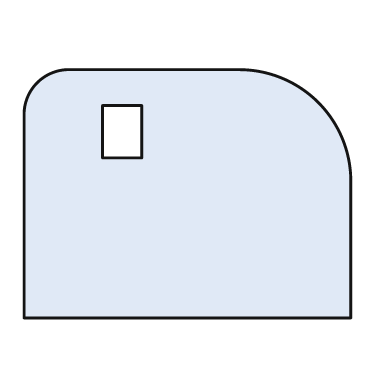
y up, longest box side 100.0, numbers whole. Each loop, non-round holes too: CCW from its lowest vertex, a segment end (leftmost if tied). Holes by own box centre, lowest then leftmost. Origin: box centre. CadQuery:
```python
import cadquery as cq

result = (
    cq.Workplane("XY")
    .moveTo(-50.0, -38.0)
    .lineTo(50.0, -38.0)
    .lineTo(50.0, 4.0)
    .threePointArc((40.0, 28.0), (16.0, 38.0))
    .lineTo(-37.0, 38.0)
    .threePointArc((-46.0, 34.0), (-50.0, 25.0))
    .close()
    .moveTo(-26.0, 11.0)
    .lineTo(-14.0, 11.0)
    .lineTo(-14.0, 27.0)
    .lineTo(-26.0, 27.0)
    .close()
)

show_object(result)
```